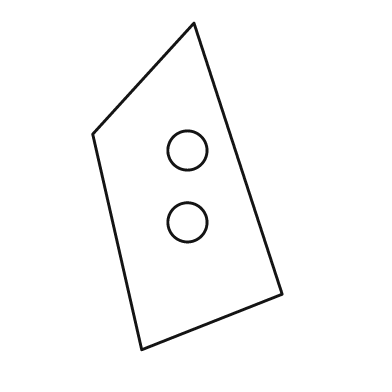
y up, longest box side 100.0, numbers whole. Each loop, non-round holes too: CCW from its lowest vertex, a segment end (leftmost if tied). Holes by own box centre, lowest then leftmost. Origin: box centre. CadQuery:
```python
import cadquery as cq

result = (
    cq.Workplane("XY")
    .moveTo(-14.0, -50.0)
    .lineTo(29.0, -33.0)
    .lineTo(2.0, 50.0)
    .lineTo(-29.0, 16.0)
    .close()
    .moveTo(0.0, -11.0)
    .circle(6.0)
    .moveTo(0.0, 11.0)
    .circle(6.0)
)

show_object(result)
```